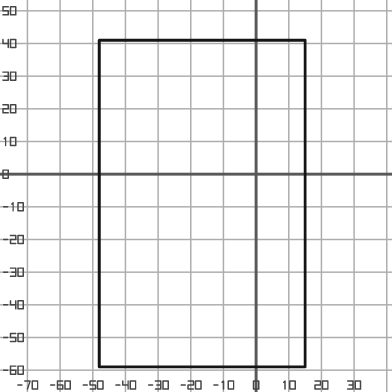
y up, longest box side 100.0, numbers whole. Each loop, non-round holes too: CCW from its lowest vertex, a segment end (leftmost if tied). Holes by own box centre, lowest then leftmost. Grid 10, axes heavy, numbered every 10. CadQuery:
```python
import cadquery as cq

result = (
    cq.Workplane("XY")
    .moveTo(-48.0, -59.0)
    .lineTo(15.0, -59.0)
    .lineTo(15.0, 41.0)
    .lineTo(-48.0, 41.0)
    .close()
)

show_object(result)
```